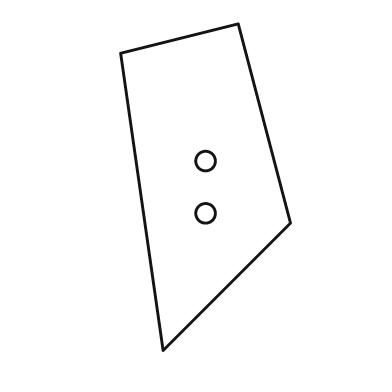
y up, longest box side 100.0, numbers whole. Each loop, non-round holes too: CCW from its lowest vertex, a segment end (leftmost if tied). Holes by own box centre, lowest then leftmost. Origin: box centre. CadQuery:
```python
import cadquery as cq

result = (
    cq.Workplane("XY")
    .moveTo(-13.0, -50.0)
    .lineTo(26.0, -11.0)
    .lineTo(10.0, 50.0)
    .lineTo(-26.0, 41.0)
    .close()
    .moveTo(0.0, -8.0)
    .circle(3.0)
    .moveTo(0.0, 8.0)
    .circle(3.0)
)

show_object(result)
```